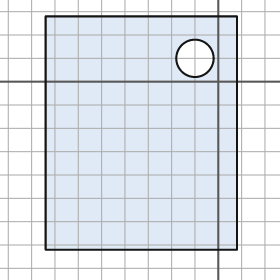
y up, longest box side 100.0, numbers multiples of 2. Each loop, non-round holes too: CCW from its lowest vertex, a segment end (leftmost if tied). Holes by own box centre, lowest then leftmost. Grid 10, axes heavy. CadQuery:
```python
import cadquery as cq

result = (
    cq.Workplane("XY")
    .moveTo(-74.0, -72.0)
    .lineTo(8.0, -72.0)
    .lineTo(8.0, 28.0)
    .lineTo(-74.0, 28.0)
    .close()
    .moveTo(-10.0, 10.0)
    .circle(8.0)
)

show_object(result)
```